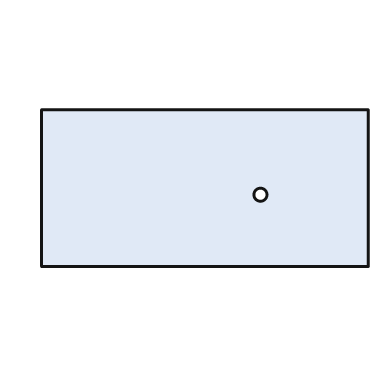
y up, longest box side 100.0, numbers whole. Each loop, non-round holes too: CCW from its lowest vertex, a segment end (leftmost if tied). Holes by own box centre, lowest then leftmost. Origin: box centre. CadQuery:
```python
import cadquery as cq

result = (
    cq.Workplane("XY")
    .moveTo(-50.0, -24.0)
    .lineTo(50.0, -24.0)
    .lineTo(50.0, 24.0)
    .lineTo(-50.0, 24.0)
    .close()
    .moveTo(17.0, -2.0)
    .circle(2.0)
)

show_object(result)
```